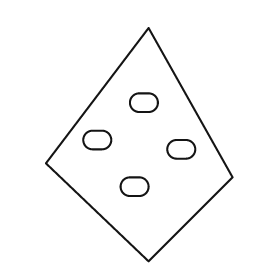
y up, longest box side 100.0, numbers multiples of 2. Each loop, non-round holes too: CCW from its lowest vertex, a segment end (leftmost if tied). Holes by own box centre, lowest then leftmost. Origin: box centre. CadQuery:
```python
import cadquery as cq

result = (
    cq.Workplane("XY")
    .moveTo(4.0, -50.0)
    .lineTo(40.0, -14.0)
    .lineTo(4.0, 50.0)
    .lineTo(-40.0, -8.0)
    .close()
    .moveTo(-4.0, -22.0)
    .lineTo(0.0, -22.0)
    .threePointArc((4.0, -18.0), (0.0, -14.0))
    .lineTo(-4.0, -14.0)
    .threePointArc((-8.0, -18.0), (-4.0, -22.0))
    .close()
    .moveTo(16.0, -6.0)
    .lineTo(20.0, -6.0)
    .threePointArc((24.0, -2.0), (20.0, 2.0))
    .lineTo(16.0, 2.0)
    .threePointArc((12.0, -2.0), (16.0, -6.0))
    .close()
    .moveTo(-20.0, -2.0)
    .lineTo(-16.0, -2.0)
    .threePointArc((-12.0, 2.0), (-16.0, 6.0))
    .lineTo(-20.0, 6.0)
    .threePointArc((-24.0, 2.0), (-20.0, -2.0))
    .close()
    .moveTo(0.0, 14.0)
    .lineTo(4.0, 14.0)
    .threePointArc((8.0, 18.0), (4.0, 22.0))
    .lineTo(0.0, 22.0)
    .threePointArc((-4.0, 18.0), (0.0, 14.0))
    .close()
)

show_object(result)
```